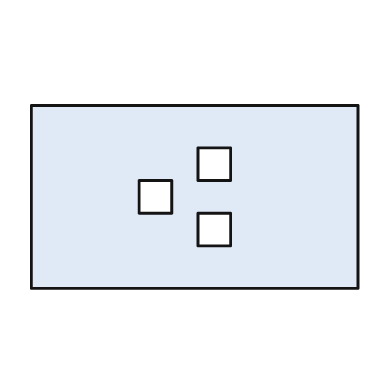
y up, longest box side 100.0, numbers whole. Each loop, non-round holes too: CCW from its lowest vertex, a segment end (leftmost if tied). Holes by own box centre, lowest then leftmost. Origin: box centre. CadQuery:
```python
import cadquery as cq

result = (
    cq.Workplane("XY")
    .moveTo(-50.0, -28.0)
    .lineTo(50.0, -28.0)
    .lineTo(50.0, 28.0)
    .lineTo(-50.0, 28.0)
    .close()
    .moveTo(1.0, -15.0)
    .lineTo(11.0, -15.0)
    .lineTo(11.0, -5.0)
    .lineTo(1.0, -5.0)
    .close()
    .moveTo(-17.0, -5.0)
    .lineTo(-7.0, -5.0)
    .lineTo(-7.0, 5.0)
    .lineTo(-17.0, 5.0)
    .close()
    .moveTo(1.0, 5.0)
    .lineTo(11.0, 5.0)
    .lineTo(11.0, 15.0)
    .lineTo(1.0, 15.0)
    .close()
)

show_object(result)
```